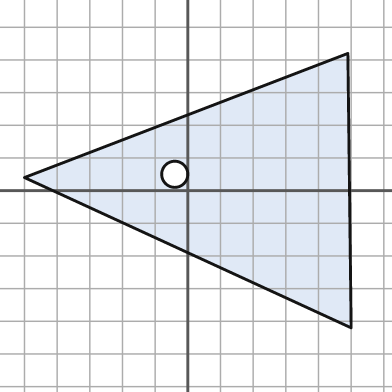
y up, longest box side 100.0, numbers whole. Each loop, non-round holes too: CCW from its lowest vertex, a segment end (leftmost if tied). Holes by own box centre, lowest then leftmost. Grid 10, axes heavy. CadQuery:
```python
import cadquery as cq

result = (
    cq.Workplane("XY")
    .moveTo(50.0, -42.0)
    .lineTo(49.0, 42.0)
    .lineTo(-50.0, 4.0)
    .close()
    .moveTo(-4.0, 5.0)
    .circle(4.0)
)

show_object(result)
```